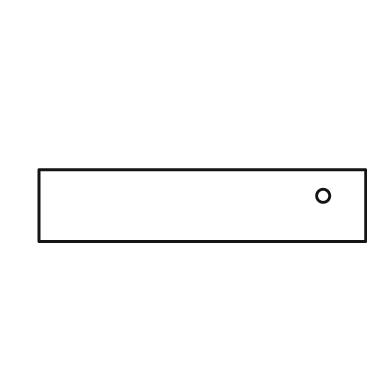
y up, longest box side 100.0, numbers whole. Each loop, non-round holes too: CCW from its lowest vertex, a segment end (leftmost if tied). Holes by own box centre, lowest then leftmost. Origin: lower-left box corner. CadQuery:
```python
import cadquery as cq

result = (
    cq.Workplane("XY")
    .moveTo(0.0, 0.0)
    .lineTo(100.0, 0.0)
    .lineTo(100.0, 22.0)
    .lineTo(0.0, 22.0)
    .close()
    .moveTo(87.0, 14.0)
    .circle(2.0)
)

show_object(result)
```